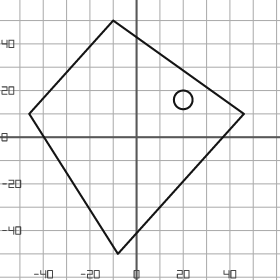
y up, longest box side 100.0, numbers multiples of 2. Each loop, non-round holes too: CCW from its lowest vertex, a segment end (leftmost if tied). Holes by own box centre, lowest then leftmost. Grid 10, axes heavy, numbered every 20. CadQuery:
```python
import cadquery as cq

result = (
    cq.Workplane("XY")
    .moveTo(-8.0, -50.0)
    .lineTo(46.0, 10.0)
    .lineTo(-10.0, 50.0)
    .lineTo(-46.0, 10.0)
    .close()
    .moveTo(20.0, 16.0)
    .circle(4.0)
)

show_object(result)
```